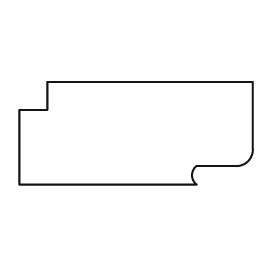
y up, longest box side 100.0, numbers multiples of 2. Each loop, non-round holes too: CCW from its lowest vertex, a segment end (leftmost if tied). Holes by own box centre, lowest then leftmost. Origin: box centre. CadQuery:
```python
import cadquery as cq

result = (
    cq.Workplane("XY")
    .moveTo(-50.0, -22.0)
    .lineTo(26.0, -22.0)
    .threePointArc((24.0, -18.0), (26.0, -14.0))
    .lineTo(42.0, -14.0)
    .threePointArc((48.0, -12.0), (50.0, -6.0))
    .lineTo(50.0, 22.0)
    .lineTo(-38.0, 22.0)
    .lineTo(-38.0, 10.0)
    .lineTo(-50.0, 10.0)
    .close()
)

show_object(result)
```